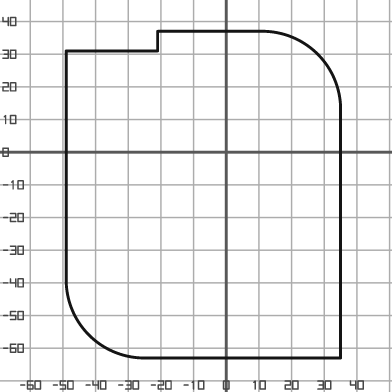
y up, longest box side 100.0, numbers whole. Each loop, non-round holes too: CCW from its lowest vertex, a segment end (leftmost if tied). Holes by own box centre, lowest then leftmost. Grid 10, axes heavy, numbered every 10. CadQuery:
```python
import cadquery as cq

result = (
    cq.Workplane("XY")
    .moveTo(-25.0, -63.0)
    .lineTo(35.0, -63.0)
    .lineTo(35.0, 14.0)
    .threePointArc((28.0, 30.0), (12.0, 37.0))
    .lineTo(-21.0, 37.0)
    .lineTo(-21.0, 31.0)
    .lineTo(-49.0, 31.0)
    .lineTo(-49.0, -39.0)
    .threePointArc((-42.0, -56.0), (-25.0, -63.0))
    .close()
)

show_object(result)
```